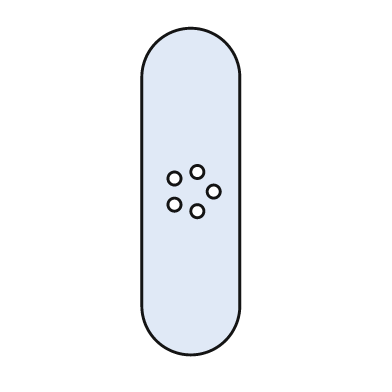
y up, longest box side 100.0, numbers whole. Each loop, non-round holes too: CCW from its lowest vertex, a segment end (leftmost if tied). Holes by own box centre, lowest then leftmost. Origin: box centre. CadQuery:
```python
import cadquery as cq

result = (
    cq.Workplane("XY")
    .moveTo(-15.0, -35.0)
    .threePointArc((0.0, -50.0), (15.0, -35.0))
    .lineTo(15.0, 35.0)
    .threePointArc((0.0, 50.0), (-15.0, 35.0))
    .close()
    .moveTo(2.0, -6.0)
    .circle(2.0)
    .moveTo(-5.0, -4.0)
    .circle(2.0)
    .moveTo(7.0, 0.0)
    .circle(2.0)
    .moveTo(-5.0, 4.0)
    .circle(2.0)
    .moveTo(2.0, 6.0)
    .circle(2.0)
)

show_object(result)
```